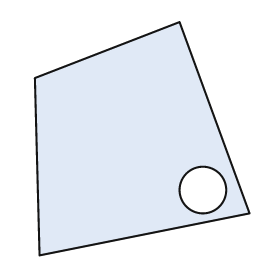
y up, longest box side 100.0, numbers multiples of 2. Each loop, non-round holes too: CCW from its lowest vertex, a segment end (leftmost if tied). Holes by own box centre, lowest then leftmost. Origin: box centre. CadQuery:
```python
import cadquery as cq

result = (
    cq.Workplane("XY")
    .moveTo(-44.0, -50.0)
    .lineTo(46.0, -32.0)
    .lineTo(16.0, 50.0)
    .lineTo(-46.0, 26.0)
    .close()
    .moveTo(26.0, -22.0)
    .circle(10.0)
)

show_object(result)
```